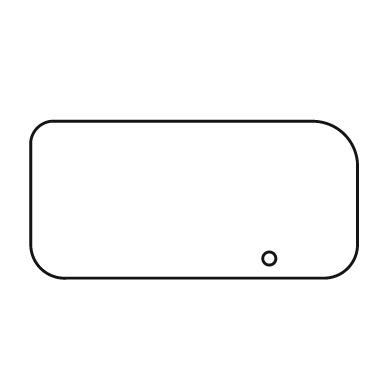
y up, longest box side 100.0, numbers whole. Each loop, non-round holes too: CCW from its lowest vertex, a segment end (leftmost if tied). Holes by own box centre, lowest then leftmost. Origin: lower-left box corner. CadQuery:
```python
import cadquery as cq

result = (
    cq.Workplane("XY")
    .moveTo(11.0, 0.0)
    .lineTo(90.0, 0.0)
    .threePointArc((97.0, 3.0), (100.0, 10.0))
    .lineTo(100.0, 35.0)
    .threePointArc((96.0, 44.0), (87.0, 48.0))
    .lineTo(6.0, 48.0)
    .threePointArc((2.0, 46.0), (0.0, 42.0))
    .lineTo(0.0, 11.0)
    .threePointArc((3.0, 3.0), (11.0, 0.0))
    .close()
    .moveTo(73.0, 6.0)
    .circle(2.0)
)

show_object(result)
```